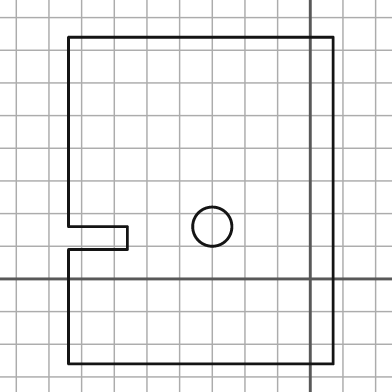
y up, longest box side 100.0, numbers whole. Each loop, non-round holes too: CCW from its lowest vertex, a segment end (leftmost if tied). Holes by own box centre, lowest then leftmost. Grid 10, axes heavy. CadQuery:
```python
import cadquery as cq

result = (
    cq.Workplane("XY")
    .moveTo(-74.0, -26.0)
    .lineTo(7.0, -26.0)
    .lineTo(7.0, 74.0)
    .lineTo(-74.0, 74.0)
    .lineTo(-74.0, 16.0)
    .lineTo(-56.0, 16.0)
    .lineTo(-56.0, 9.0)
    .lineTo(-74.0, 9.0)
    .close()
    .moveTo(-30.0, 16.0)
    .circle(6.0)
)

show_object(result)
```